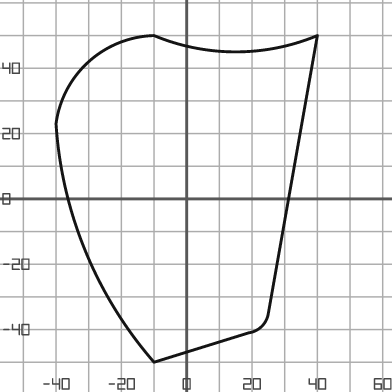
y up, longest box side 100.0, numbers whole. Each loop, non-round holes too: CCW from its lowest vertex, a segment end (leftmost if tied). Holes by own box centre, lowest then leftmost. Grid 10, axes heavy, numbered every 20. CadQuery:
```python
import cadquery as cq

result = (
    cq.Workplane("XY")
    .moveTo(-10.0, -50.0)
    .lineTo(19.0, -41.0)
    .threePointArc((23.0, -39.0), (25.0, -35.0))
    .lineTo(40.0, 50.0)
    .threePointArc((15.0, 45.0), (-10.0, 50.0))
    .threePointArc((-30.0, 42.0), (-40.0, 23.0))
    .threePointArc((-31.0, -16.0), (-10.0, -50.0))
    .close()
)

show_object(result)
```